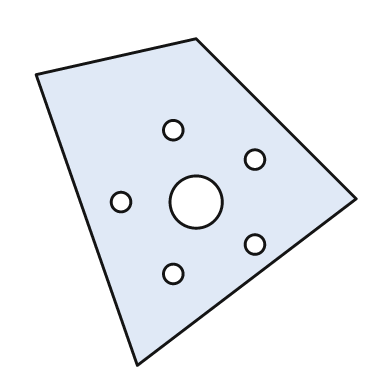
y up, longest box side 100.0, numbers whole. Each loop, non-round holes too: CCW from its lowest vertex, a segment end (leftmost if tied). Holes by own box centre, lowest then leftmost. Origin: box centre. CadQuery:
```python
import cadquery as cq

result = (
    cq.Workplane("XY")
    .moveTo(-18.0, -50.0)
    .lineTo(49.0, 1.0)
    .lineTo(0.0, 50.0)
    .lineTo(-49.0, 39.0)
    .close()
    .moveTo(-7.0, -22.0)
    .circle(3.0)
    .moveTo(18.0, -13.0)
    .circle(3.0)
    .moveTo(-23.0, 0.0)
    .circle(3.0)
    .moveTo(0.0, 0.0)
    .circle(8.0)
    .moveTo(18.0, 13.0)
    .circle(3.0)
    .moveTo(-7.0, 22.0)
    .circle(3.0)
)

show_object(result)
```